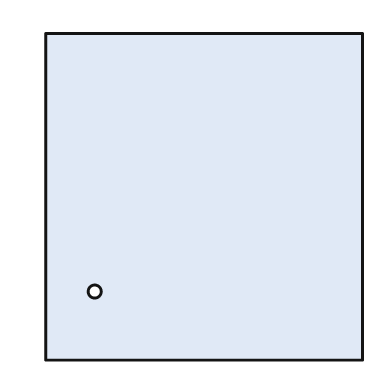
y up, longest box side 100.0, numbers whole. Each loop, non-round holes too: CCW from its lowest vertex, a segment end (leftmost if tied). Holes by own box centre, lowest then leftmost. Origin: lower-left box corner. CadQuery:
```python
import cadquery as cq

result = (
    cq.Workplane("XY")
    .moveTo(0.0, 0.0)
    .lineTo(97.0, 0.0)
    .lineTo(97.0, 100.0)
    .lineTo(0.0, 100.0)
    .close()
    .moveTo(15.0, 21.0)
    .circle(2.0)
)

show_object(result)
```